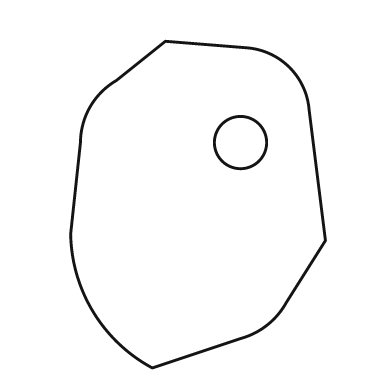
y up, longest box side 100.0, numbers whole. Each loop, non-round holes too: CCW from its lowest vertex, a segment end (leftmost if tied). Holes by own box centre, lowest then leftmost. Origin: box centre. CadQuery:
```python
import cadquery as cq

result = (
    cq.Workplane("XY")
    .moveTo(-14.0, -50.0)
    .lineTo(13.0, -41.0)
    .threePointArc((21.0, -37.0), (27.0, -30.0))
    .lineTo(39.0, -11.0)
    .lineTo(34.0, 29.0)
    .threePointArc((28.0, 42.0), (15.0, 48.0))
    .lineTo(-10.0, 50.0)
    .lineTo(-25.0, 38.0)
    .threePointArc((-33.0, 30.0), (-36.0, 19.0))
    .lineTo(-39.0, -9.0)
    .threePointArc((-32.0, -33.0), (-14.0, -50.0))
    .close()
    .moveTo(13.0, 19.0)
    .circle(8.0)
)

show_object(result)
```